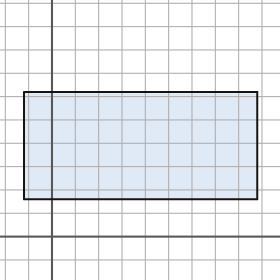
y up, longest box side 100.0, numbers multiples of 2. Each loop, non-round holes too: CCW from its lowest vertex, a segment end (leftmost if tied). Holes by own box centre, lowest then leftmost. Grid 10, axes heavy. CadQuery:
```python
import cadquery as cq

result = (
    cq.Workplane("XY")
    .moveTo(-12.0, 16.0)
    .lineTo(88.0, 16.0)
    .lineTo(88.0, 62.0)
    .lineTo(-12.0, 62.0)
    .close()
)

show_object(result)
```